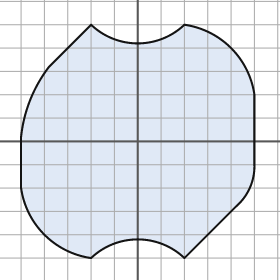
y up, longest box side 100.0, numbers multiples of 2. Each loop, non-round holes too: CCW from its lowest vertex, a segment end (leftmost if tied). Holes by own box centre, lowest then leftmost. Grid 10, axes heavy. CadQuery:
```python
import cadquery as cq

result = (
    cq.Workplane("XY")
    .moveTo(-20.0, -50.0)
    .threePointArc((0.0, -42.0), (20.0, -50.0))
    .lineTo(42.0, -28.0)
    .threePointArc((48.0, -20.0), (50.0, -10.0))
    .lineTo(50.0, 20.0)
    .threePointArc((40.0, 40.0), (20.0, 50.0))
    .threePointArc((0.0, 42.0), (-20.0, 50.0))
    .lineTo(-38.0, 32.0)
    .threePointArc((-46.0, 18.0), (-50.0, 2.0))
    .lineTo(-50.0, -20.0)
    .threePointArc((-40.0, -40.0), (-20.0, -50.0))
    .close()
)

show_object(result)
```